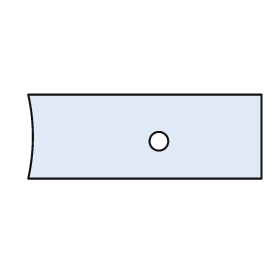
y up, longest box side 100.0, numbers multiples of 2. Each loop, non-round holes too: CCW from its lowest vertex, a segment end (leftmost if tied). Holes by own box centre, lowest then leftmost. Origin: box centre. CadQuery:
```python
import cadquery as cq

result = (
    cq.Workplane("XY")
    .moveTo(-50.0, -18.0)
    .lineTo(50.0, -18.0)
    .lineTo(50.0, 18.0)
    .lineTo(-50.0, 18.0)
    .threePointArc((-48.0, 0.0), (-50.0, -18.0))
    .close()
    .moveTo(6.0, -2.0)
    .circle(4.0)
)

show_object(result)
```